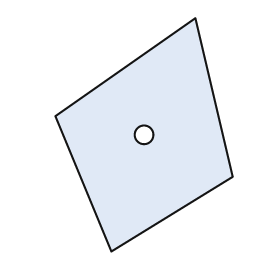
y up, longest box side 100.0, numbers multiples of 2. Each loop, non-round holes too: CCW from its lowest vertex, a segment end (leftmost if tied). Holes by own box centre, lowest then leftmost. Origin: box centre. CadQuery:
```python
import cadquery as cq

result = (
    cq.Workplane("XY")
    .moveTo(-14.0, -50.0)
    .lineTo(38.0, -18.0)
    .lineTo(22.0, 50.0)
    .lineTo(-38.0, 8.0)
    .close()
    .moveTo(0.0, 0.0)
    .circle(4.0)
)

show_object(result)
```